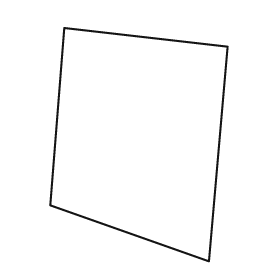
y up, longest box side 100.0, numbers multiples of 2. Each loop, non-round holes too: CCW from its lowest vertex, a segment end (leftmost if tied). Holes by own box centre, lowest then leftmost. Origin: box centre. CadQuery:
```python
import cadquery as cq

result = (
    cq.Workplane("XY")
    .moveTo(30.0, -50.0)
    .lineTo(38.0, 42.0)
    .lineTo(-32.0, 50.0)
    .lineTo(-38.0, -26.0)
    .close()
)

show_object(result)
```